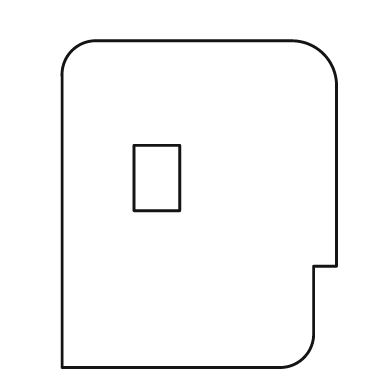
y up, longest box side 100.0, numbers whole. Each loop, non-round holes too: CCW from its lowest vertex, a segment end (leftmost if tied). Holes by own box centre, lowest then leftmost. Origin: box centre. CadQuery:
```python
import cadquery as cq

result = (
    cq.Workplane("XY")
    .moveTo(-42.0, -50.0)
    .lineTo(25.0, -50.0)
    .threePointArc((32.0, -47.0), (35.0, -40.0))
    .lineTo(35.0, -19.0)
    .lineTo(42.0, -19.0)
    .lineTo(42.0, 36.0)
    .threePointArc((38.0, 46.0), (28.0, 50.0))
    .lineTo(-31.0, 50.0)
    .threePointArc((-39.0, 47.0), (-42.0, 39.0))
    .close()
    .moveTo(-20.0, -2.0)
    .lineTo(-6.0, -2.0)
    .lineTo(-6.0, 18.0)
    .lineTo(-20.0, 18.0)
    .close()
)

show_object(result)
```